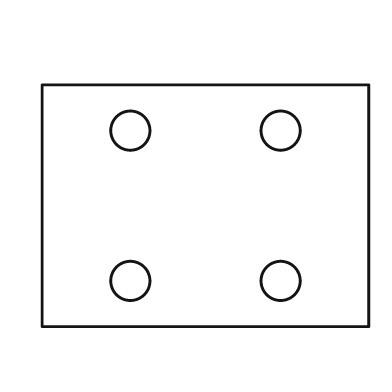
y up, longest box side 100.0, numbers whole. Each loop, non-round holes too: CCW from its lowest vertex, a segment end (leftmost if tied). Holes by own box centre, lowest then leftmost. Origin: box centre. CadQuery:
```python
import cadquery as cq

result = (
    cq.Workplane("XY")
    .moveTo(-50.0, -37.0)
    .lineTo(50.0, -37.0)
    .lineTo(50.0, 37.0)
    .lineTo(-50.0, 37.0)
    .close()
    .moveTo(-23.0, -23.0)
    .circle(6.0)
    .moveTo(23.0, -23.0)
    .circle(6.0)
    .moveTo(-23.0, 23.0)
    .circle(6.0)
    .moveTo(23.0, 23.0)
    .circle(6.0)
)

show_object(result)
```